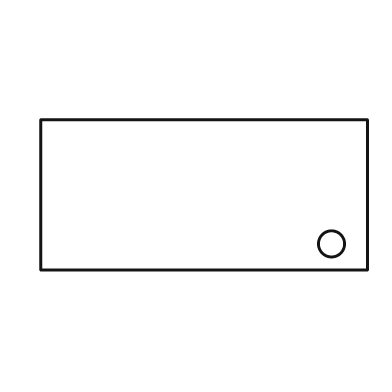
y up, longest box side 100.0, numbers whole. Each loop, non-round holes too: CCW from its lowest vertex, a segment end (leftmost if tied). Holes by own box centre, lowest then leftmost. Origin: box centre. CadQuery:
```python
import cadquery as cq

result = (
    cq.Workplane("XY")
    .moveTo(-50.0, -23.0)
    .lineTo(50.0, -23.0)
    .lineTo(50.0, 23.0)
    .lineTo(-50.0, 23.0)
    .close()
    .moveTo(39.0, -15.0)
    .circle(4.0)
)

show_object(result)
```